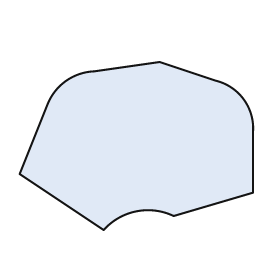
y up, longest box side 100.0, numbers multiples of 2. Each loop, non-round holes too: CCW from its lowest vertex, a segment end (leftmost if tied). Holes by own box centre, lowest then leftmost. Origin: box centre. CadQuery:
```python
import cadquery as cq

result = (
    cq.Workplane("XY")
    .moveTo(-14.0, -36.0)
    .threePointArc((0.0, -28.0), (16.0, -30.0))
    .lineTo(50.0, -20.0)
    .lineTo(50.0, 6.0)
    .threePointArc((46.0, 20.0), (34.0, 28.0))
    .lineTo(10.0, 36.0)
    .lineTo(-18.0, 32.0)
    .threePointArc((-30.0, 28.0), (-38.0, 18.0))
    .lineTo(-50.0, -12.0)
    .close()
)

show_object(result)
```